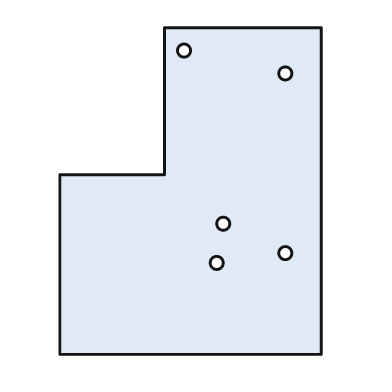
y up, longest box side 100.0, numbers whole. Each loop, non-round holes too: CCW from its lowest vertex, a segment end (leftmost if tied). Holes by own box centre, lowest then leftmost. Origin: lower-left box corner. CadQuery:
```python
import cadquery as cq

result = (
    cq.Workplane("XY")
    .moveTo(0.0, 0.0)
    .lineTo(80.0, 0.0)
    .lineTo(80.0, 100.0)
    .lineTo(32.0, 100.0)
    .lineTo(32.0, 55.0)
    .lineTo(0.0, 55.0)
    .close()
    .moveTo(48.0, 28.0)
    .circle(2.0)
    .moveTo(69.0, 31.0)
    .circle(2.0)
    .moveTo(50.0, 40.0)
    .circle(2.0)
    .moveTo(69.0, 86.0)
    .circle(2.0)
    .moveTo(38.0, 93.0)
    .circle(2.0)
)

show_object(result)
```